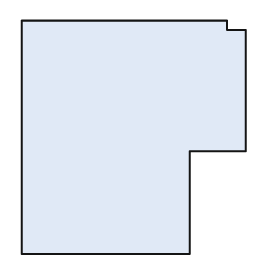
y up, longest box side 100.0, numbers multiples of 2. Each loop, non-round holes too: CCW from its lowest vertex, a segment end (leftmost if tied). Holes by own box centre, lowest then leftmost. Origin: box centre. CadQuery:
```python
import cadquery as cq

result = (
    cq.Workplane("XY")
    .moveTo(-48.0, -50.0)
    .lineTo(24.0, -50.0)
    .lineTo(24.0, -6.0)
    .lineTo(48.0, -6.0)
    .lineTo(48.0, 46.0)
    .lineTo(40.0, 46.0)
    .lineTo(40.0, 50.0)
    .lineTo(-48.0, 50.0)
    .close()
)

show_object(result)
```